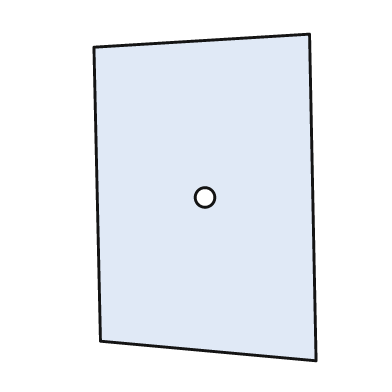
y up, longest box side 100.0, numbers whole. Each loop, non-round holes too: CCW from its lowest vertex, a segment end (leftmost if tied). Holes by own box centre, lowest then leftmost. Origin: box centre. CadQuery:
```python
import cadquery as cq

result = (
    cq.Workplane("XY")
    .moveTo(34.0, -50.0)
    .lineTo(32.0, 50.0)
    .lineTo(-34.0, 46.0)
    .lineTo(-32.0, -44.0)
    .close()
    .moveTo(0.0, 0.0)
    .circle(3.0)
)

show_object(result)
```